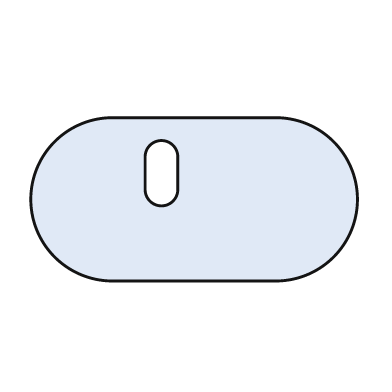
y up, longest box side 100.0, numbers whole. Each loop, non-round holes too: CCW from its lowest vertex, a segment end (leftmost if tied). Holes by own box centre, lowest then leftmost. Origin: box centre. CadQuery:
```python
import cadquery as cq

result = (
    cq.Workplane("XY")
    .moveTo(-25.0, -25.0)
    .lineTo(25.0, -25.0)
    .threePointArc((50.0, 0.0), (25.0, 25.0))
    .lineTo(-25.0, 25.0)
    .threePointArc((-50.0, 0.0), (-25.0, -25.0))
    .close()
    .moveTo(-15.0, 3.0)
    .threePointArc((-10.0, -2.0), (-5.0, 3.0))
    .lineTo(-5.0, 13.0)
    .threePointArc((-10.0, 18.0), (-15.0, 13.0))
    .close()
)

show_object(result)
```